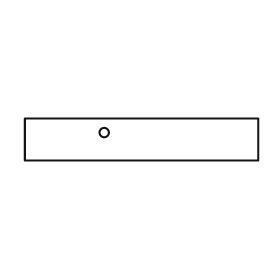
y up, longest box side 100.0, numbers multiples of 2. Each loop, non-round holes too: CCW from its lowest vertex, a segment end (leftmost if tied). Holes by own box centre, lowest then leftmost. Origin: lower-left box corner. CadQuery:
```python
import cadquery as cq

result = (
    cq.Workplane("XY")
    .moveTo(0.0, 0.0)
    .lineTo(100.0, 0.0)
    .lineTo(100.0, 18.0)
    .lineTo(0.0, 18.0)
    .close()
    .moveTo(34.0, 12.0)
    .circle(2.0)
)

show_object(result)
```